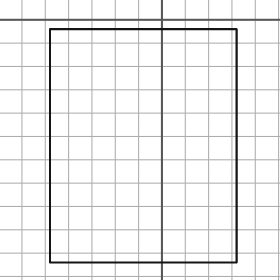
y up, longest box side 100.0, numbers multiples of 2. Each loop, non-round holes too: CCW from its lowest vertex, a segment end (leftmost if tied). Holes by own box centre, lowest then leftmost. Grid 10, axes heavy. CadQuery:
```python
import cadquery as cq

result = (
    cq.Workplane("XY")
    .moveTo(-48.0, -104.0)
    .lineTo(32.0, -104.0)
    .lineTo(32.0, -4.0)
    .lineTo(-48.0, -4.0)
    .close()
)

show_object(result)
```